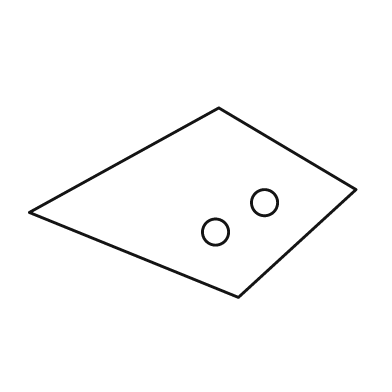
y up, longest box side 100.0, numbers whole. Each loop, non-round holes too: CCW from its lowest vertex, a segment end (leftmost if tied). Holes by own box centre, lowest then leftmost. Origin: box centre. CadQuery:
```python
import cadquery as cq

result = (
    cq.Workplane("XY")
    .moveTo(14.0, -29.0)
    .lineTo(50.0, 4.0)
    .lineTo(8.0, 29.0)
    .lineTo(-50.0, -3.0)
    .close()
    .moveTo(7.0, -9.0)
    .circle(4.0)
    .moveTo(22.0, 0.0)
    .circle(4.0)
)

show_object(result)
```